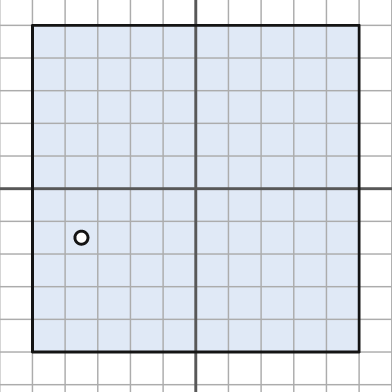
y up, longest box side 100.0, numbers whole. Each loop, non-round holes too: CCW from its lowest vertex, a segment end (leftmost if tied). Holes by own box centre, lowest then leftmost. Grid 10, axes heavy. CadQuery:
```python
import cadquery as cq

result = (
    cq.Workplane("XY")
    .moveTo(-50.0, -50.0)
    .lineTo(50.0, -50.0)
    .lineTo(50.0, 50.0)
    .lineTo(-50.0, 50.0)
    .close()
    .moveTo(-35.0, -15.0)
    .circle(2.0)
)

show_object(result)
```